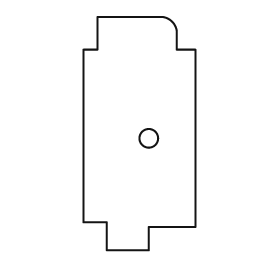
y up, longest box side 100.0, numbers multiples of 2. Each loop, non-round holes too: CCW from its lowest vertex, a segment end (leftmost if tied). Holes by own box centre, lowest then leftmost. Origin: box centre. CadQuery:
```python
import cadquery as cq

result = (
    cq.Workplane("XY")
    .moveTo(-14.0, -50.0)
    .lineTo(4.0, -50.0)
    .lineTo(4.0, -40.0)
    .lineTo(24.0, -40.0)
    .lineTo(24.0, 36.0)
    .lineTo(16.0, 36.0)
    .lineTo(16.0, 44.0)
    .threePointArc((14.0, 48.0), (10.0, 50.0))
    .lineTo(-18.0, 50.0)
    .lineTo(-18.0, 36.0)
    .lineTo(-24.0, 36.0)
    .lineTo(-24.0, -38.0)
    .lineTo(-14.0, -38.0)
    .close()
    .moveTo(4.0, -2.0)
    .circle(4.0)
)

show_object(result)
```